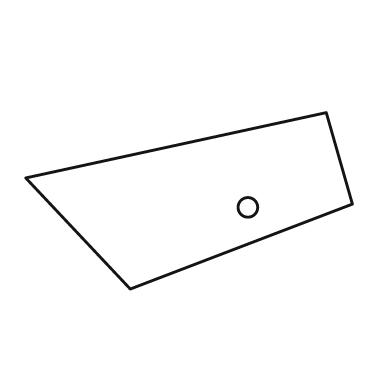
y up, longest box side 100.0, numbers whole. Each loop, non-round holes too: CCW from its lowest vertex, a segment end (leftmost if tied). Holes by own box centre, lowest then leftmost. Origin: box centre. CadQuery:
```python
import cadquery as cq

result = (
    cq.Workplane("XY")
    .moveTo(-18.0, -27.0)
    .lineTo(50.0, -1.0)
    .lineTo(42.0, 27.0)
    .lineTo(-50.0, 7.0)
    .close()
    .moveTo(18.0, -2.0)
    .circle(3.0)
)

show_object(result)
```